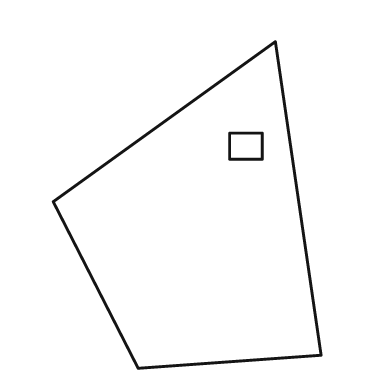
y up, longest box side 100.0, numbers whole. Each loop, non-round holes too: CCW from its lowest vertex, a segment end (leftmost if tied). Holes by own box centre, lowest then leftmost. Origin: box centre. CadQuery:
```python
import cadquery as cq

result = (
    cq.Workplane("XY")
    .moveTo(-15.0, -50.0)
    .lineTo(41.0, -46.0)
    .lineTo(27.0, 50.0)
    .lineTo(-41.0, 1.0)
    .close()
    .moveTo(13.0, 14.0)
    .lineTo(23.0, 14.0)
    .lineTo(23.0, 22.0)
    .lineTo(13.0, 22.0)
    .close()
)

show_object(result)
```